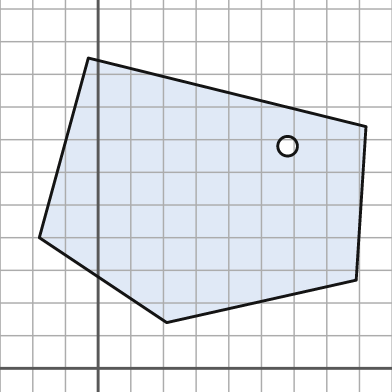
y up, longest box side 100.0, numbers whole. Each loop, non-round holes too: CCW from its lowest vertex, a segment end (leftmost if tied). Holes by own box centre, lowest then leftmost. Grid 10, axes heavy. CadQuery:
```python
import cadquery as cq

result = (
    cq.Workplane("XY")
    .moveTo(21.0, 14.0)
    .lineTo(79.0, 27.0)
    .lineTo(82.0, 74.0)
    .lineTo(-3.0, 95.0)
    .lineTo(-18.0, 40.0)
    .close()
    .moveTo(58.0, 68.0)
    .circle(3.0)
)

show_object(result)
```